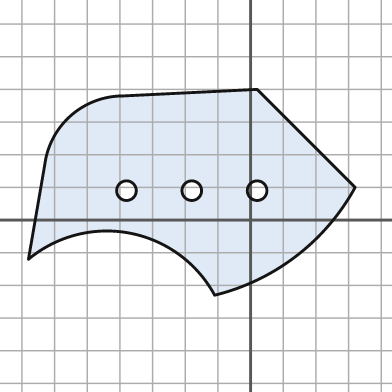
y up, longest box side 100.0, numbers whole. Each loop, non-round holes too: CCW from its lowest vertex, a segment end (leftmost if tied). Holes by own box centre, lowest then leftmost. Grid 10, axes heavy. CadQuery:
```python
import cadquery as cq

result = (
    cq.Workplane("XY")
    .moveTo(-11.0, -23.0)
    .threePointArc((14.0, -11.0), (32.0, 10.0))
    .lineTo(2.0, 40.0)
    .lineTo(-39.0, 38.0)
    .threePointArc((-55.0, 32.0), (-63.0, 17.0))
    .lineTo(-68.0, -12.0)
    .threePointArc((-37.0, -4.0), (-11.0, -23.0))
    .close()
    .moveTo(-38.0, 9.0)
    .circle(3.0)
    .moveTo(-18.0, 9.0)
    .circle(3.0)
    .moveTo(2.0, 9.0)
    .circle(3.0)
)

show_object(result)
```